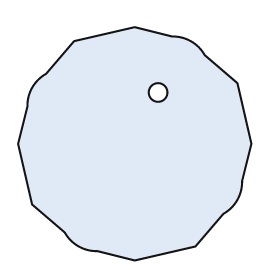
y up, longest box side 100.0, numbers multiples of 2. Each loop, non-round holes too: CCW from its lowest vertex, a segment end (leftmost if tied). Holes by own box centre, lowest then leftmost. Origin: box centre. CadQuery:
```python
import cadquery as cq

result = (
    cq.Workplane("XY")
    .moveTo(0.0, -50.0)
    .lineTo(26.0, -44.0)
    .lineTo(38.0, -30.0)
    .threePointArc((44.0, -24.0), (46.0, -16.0))
    .lineTo(50.0, 0.0)
    .lineTo(44.0, 26.0)
    .lineTo(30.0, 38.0)
    .threePointArc((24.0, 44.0), (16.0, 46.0))
    .lineTo(0.0, 50.0)
    .lineTo(-26.0, 44.0)
    .lineTo(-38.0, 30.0)
    .threePointArc((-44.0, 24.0), (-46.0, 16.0))
    .lineTo(-50.0, 0.0)
    .lineTo(-44.0, -26.0)
    .lineTo(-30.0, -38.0)
    .threePointArc((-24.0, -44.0), (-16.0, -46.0))
    .close()
    .moveTo(10.0, 22.0)
    .circle(4.0)
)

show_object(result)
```